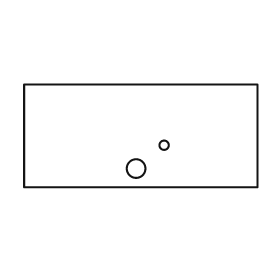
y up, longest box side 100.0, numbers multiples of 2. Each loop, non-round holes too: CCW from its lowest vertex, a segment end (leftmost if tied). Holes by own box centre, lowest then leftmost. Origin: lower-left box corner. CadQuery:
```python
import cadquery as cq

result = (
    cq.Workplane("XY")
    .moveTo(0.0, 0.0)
    .lineTo(100.0, 0.0)
    .lineTo(100.0, 44.0)
    .lineTo(0.0, 44.0)
    .close()
    .moveTo(48.0, 8.0)
    .circle(4.0)
    .moveTo(60.0, 18.0)
    .circle(2.0)
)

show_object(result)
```